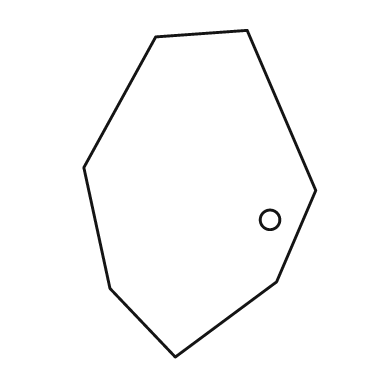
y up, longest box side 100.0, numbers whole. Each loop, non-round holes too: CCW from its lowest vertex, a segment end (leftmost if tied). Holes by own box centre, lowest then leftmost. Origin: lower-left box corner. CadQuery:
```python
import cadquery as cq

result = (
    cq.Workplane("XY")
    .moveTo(28.0, 0.0)
    .lineTo(59.0, 23.0)
    .lineTo(71.0, 51.0)
    .lineTo(50.0, 100.0)
    .lineTo(22.0, 98.0)
    .lineTo(0.0, 58.0)
    .lineTo(8.0, 21.0)
    .close()
    .moveTo(57.0, 42.0)
    .circle(3.0)
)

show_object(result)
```